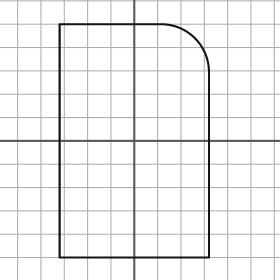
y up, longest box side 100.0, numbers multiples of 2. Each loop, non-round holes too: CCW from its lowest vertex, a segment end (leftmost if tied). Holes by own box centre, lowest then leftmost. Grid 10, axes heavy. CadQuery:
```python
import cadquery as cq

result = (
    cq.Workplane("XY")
    .moveTo(-32.0, -50.0)
    .lineTo(32.0, -50.0)
    .lineTo(32.0, 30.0)
    .threePointArc((26.0, 44.0), (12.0, 50.0))
    .lineTo(-32.0, 50.0)
    .close()
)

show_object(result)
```